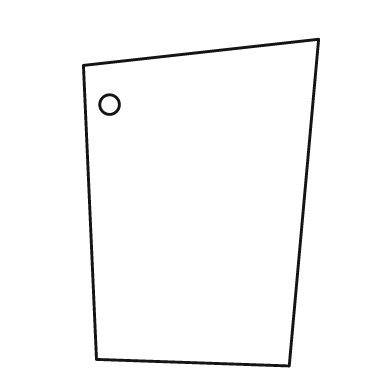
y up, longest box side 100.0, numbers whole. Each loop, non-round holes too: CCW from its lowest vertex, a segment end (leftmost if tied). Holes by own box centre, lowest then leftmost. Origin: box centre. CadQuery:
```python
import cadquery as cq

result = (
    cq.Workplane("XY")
    .moveTo(27.0, -50.0)
    .lineTo(36.0, 50.0)
    .lineTo(-36.0, 42.0)
    .lineTo(-32.0, -48.0)
    .close()
    .moveTo(-28.0, 30.0)
    .circle(3.0)
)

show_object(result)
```